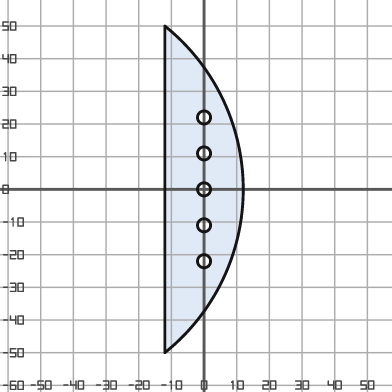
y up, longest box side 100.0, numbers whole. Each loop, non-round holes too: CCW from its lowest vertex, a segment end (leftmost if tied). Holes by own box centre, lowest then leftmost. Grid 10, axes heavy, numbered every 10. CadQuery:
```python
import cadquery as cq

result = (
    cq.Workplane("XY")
    .moveTo(-12.0, -50.0)
    .threePointArc((12.0, 0.0), (-12.0, 50.0))
    .close()
    .moveTo(0.0, -22.0)
    .circle(2.0)
    .moveTo(0.0, -11.0)
    .circle(2.0)
    .moveTo(0.0, 0.0)
    .circle(2.0)
    .moveTo(0.0, 11.0)
    .circle(2.0)
    .moveTo(0.0, 22.0)
    .circle(2.0)
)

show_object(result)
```